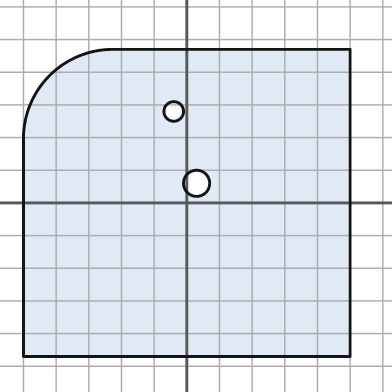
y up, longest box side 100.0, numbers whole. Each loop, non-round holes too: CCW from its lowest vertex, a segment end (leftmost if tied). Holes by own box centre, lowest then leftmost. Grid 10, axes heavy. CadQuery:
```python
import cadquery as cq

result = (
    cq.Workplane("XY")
    .moveTo(-50.0, -47.0)
    .lineTo(50.0, -47.0)
    .lineTo(50.0, 47.0)
    .lineTo(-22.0, 47.0)
    .threePointArc((-42.0, 39.0), (-50.0, 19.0))
    .close()
    .moveTo(3.0, 6.0)
    .circle(4.0)
    .moveTo(-4.0, 28.0)
    .circle(3.0)
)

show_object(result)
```